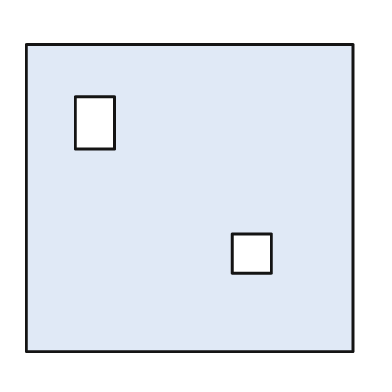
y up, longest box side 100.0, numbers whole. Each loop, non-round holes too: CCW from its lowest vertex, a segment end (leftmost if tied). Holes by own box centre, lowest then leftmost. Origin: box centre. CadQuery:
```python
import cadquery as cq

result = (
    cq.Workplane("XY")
    .moveTo(-50.0, -47.0)
    .lineTo(50.0, -47.0)
    .lineTo(50.0, 47.0)
    .lineTo(-50.0, 47.0)
    .close()
    .moveTo(13.0, -23.0)
    .lineTo(25.0, -23.0)
    .lineTo(25.0, -11.0)
    .lineTo(13.0, -11.0)
    .close()
    .moveTo(-35.0, 15.0)
    .lineTo(-23.0, 15.0)
    .lineTo(-23.0, 31.0)
    .lineTo(-35.0, 31.0)
    .close()
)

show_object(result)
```